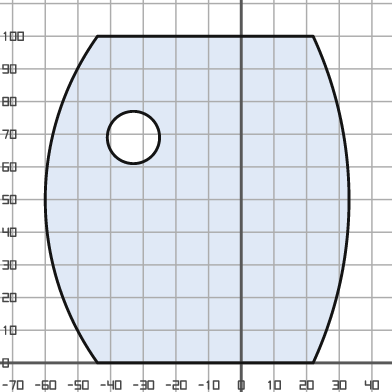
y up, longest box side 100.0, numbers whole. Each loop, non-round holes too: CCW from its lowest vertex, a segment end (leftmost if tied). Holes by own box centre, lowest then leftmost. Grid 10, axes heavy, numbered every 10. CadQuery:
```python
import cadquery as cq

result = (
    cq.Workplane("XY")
    .moveTo(-44.0, 0.0)
    .lineTo(22.0, 0.0)
    .threePointArc((33.0, 50.0), (22.0, 100.0))
    .lineTo(-44.0, 100.0)
    .threePointArc((-60.0, 50.0), (-44.0, 0.0))
    .close()
    .moveTo(-33.0, 69.0)
    .circle(8.0)
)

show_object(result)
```